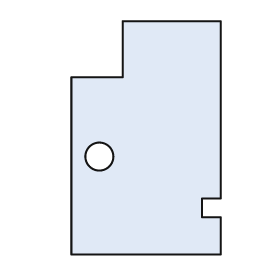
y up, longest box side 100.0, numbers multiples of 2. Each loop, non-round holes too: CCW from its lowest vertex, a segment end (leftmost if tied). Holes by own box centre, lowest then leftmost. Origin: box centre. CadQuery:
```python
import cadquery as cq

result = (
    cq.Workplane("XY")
    .moveTo(-32.0, -50.0)
    .lineTo(32.0, -50.0)
    .lineTo(32.0, -34.0)
    .lineTo(24.0, -34.0)
    .lineTo(24.0, -26.0)
    .lineTo(32.0, -26.0)
    .lineTo(32.0, 50.0)
    .lineTo(-10.0, 50.0)
    .lineTo(-10.0, 26.0)
    .lineTo(-32.0, 26.0)
    .close()
    .moveTo(-20.0, -8.0)
    .circle(6.0)
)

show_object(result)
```